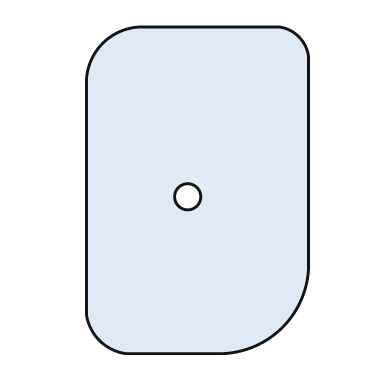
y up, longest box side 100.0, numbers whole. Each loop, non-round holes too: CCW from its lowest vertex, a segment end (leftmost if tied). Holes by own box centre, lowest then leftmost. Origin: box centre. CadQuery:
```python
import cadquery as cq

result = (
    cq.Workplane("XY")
    .moveTo(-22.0, -50.0)
    .lineTo(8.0, -50.0)
    .threePointArc((26.0, -42.0), (34.0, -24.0))
    .lineTo(34.0, 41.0)
    .threePointArc((31.0, 47.0), (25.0, 50.0))
    .lineTo(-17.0, 50.0)
    .threePointArc((-29.0, 45.0), (-34.0, 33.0))
    .lineTo(-34.0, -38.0)
    .threePointArc((-30.0, -46.0), (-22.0, -50.0))
    .close()
    .moveTo(-3.0, -2.0)
    .circle(4.0)
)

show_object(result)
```